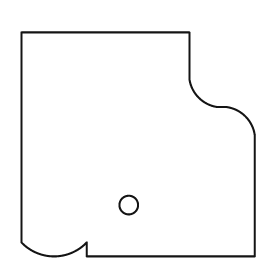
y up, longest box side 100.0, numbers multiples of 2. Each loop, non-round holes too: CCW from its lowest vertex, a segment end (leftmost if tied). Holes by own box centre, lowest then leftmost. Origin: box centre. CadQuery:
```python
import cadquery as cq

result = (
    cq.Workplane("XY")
    .moveTo(-22.0, -48.0)
    .lineTo(50.0, -48.0)
    .lineTo(50.0, 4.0)
    .threePointArc((46.0, 12.0), (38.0, 16.0))
    .lineTo(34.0, 16.0)
    .threePointArc((26.0, 20.0), (22.0, 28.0))
    .lineTo(22.0, 48.0)
    .lineTo(-50.0, 48.0)
    .lineTo(-50.0, -42.0)
    .threePointArc((-36.0, -48.0), (-22.0, -42.0))
    .close()
    .moveTo(-4.0, -26.0)
    .circle(4.0)
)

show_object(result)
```